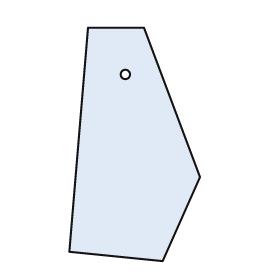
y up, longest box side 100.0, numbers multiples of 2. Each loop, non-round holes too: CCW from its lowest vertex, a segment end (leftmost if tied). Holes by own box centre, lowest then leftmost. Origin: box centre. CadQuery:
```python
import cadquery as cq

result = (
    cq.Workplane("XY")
    .moveTo(12.0, -50.0)
    .lineTo(28.0, -14.0)
    .lineTo(4.0, 50.0)
    .lineTo(-20.0, 50.0)
    .lineTo(-28.0, -46.0)
    .close()
    .moveTo(-4.0, 30.0)
    .circle(2.0)
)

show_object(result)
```